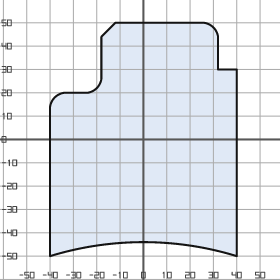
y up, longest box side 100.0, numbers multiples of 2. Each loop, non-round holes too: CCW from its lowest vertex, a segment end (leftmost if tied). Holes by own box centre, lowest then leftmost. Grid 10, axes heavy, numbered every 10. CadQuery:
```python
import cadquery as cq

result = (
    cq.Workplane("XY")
    .moveTo(-40.0, -50.0)
    .threePointArc((0.0, -44.0), (40.0, -50.0))
    .lineTo(40.0, 30.0)
    .lineTo(32.0, 30.0)
    .lineTo(32.0, 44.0)
    .threePointArc((30.0, 48.0), (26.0, 50.0))
    .lineTo(-12.0, 50.0)
    .lineTo(-18.0, 44.0)
    .lineTo(-18.0, 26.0)
    .threePointArc((-20.0, 22.0), (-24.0, 20.0))
    .lineTo(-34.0, 20.0)
    .threePointArc((-38.0, 18.0), (-40.0, 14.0))
    .close()
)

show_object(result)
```